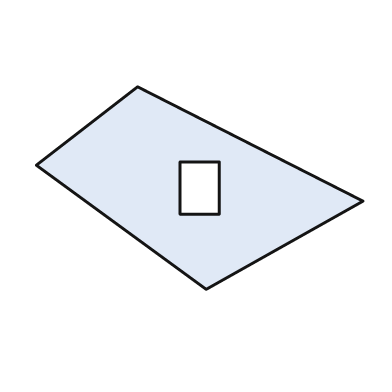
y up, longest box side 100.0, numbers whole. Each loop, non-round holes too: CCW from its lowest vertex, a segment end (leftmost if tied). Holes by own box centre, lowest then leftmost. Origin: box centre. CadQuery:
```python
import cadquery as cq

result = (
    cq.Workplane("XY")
    .moveTo(2.0, -31.0)
    .lineTo(50.0, -4.0)
    .lineTo(-19.0, 31.0)
    .lineTo(-50.0, 7.0)
    .close()
    .moveTo(-6.0, -8.0)
    .lineTo(6.0, -8.0)
    .lineTo(6.0, 8.0)
    .lineTo(-6.0, 8.0)
    .close()
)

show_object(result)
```